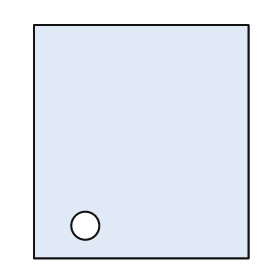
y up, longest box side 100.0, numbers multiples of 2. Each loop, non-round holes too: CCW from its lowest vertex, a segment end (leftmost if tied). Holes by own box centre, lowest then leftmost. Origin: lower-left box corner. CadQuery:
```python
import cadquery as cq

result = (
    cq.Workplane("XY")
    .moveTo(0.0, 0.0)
    .lineTo(92.0, 0.0)
    .lineTo(92.0, 100.0)
    .lineTo(0.0, 100.0)
    .close()
    .moveTo(22.0, 14.0)
    .circle(6.0)
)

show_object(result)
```